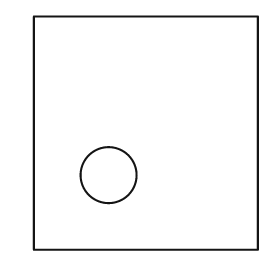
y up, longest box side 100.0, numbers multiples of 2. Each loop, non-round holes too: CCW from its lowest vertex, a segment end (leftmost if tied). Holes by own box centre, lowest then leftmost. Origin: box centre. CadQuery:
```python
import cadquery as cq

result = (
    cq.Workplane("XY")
    .moveTo(-48.0, -50.0)
    .lineTo(48.0, -50.0)
    .lineTo(48.0, 50.0)
    .lineTo(-48.0, 50.0)
    .close()
    .moveTo(-16.0, -18.0)
    .circle(12.0)
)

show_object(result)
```